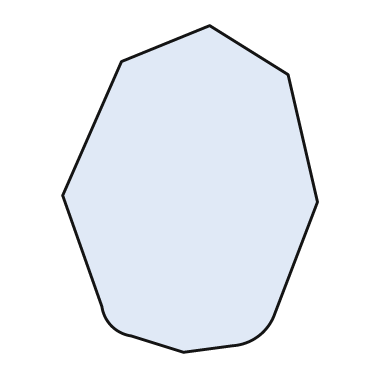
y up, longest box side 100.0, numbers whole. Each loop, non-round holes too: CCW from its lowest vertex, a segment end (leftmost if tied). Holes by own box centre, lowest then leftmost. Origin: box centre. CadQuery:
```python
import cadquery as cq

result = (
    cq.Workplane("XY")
    .moveTo(-2.0, -50.0)
    .lineTo(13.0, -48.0)
    .threePointArc((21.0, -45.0), (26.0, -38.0))
    .lineTo(39.0, -4.0)
    .lineTo(30.0, 35.0)
    .lineTo(6.0, 50.0)
    .lineTo(-21.0, 39.0)
    .lineTo(-39.0, -2.0)
    .lineTo(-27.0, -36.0)
    .threePointArc((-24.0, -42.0), (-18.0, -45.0))
    .close()
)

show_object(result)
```